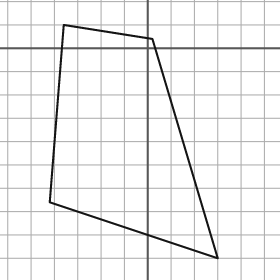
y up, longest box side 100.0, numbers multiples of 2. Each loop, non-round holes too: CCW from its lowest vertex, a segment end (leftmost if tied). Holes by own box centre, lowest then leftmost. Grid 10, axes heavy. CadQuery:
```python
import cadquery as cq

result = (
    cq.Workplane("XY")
    .moveTo(30.0, -90.0)
    .lineTo(2.0, 4.0)
    .lineTo(-36.0, 10.0)
    .lineTo(-42.0, -66.0)
    .close()
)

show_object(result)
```